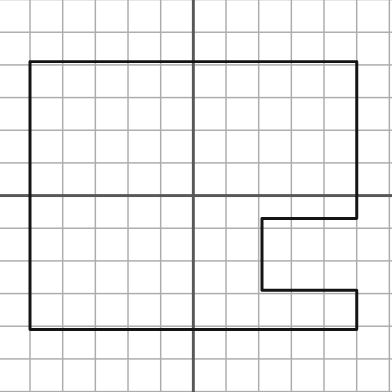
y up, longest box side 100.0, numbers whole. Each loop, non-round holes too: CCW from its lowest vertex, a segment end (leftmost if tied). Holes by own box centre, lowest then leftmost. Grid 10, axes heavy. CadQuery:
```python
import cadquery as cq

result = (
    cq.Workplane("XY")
    .moveTo(-50.0, -41.0)
    .lineTo(50.0, -41.0)
    .lineTo(50.0, -29.0)
    .lineTo(21.0, -29.0)
    .lineTo(21.0, -7.0)
    .lineTo(50.0, -7.0)
    .lineTo(50.0, 41.0)
    .lineTo(-50.0, 41.0)
    .close()
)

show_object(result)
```